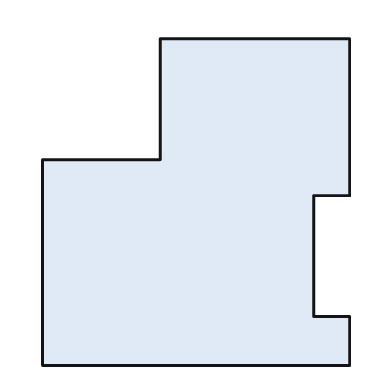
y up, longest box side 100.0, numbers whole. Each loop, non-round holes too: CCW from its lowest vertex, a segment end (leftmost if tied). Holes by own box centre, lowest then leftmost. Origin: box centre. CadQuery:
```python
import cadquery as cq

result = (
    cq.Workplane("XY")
    .moveTo(-47.0, -50.0)
    .lineTo(47.0, -50.0)
    .lineTo(47.0, -35.0)
    .lineTo(36.0, -35.0)
    .lineTo(36.0, 2.0)
    .lineTo(47.0, 2.0)
    .lineTo(47.0, 50.0)
    .lineTo(-11.0, 50.0)
    .lineTo(-11.0, 13.0)
    .lineTo(-47.0, 13.0)
    .close()
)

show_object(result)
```